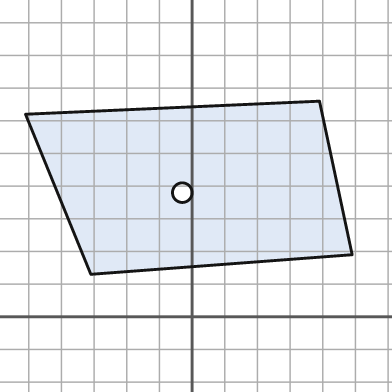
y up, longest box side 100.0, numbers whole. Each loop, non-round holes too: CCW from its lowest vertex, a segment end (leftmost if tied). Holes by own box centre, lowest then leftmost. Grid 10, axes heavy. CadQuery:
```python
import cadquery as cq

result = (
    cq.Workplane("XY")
    .moveTo(-31.0, 13.0)
    .lineTo(49.0, 19.0)
    .lineTo(39.0, 66.0)
    .lineTo(-51.0, 62.0)
    .close()
    .moveTo(-3.0, 38.0)
    .circle(3.0)
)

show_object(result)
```